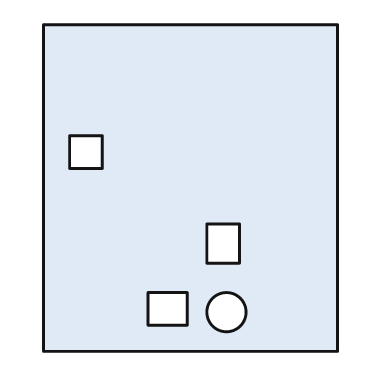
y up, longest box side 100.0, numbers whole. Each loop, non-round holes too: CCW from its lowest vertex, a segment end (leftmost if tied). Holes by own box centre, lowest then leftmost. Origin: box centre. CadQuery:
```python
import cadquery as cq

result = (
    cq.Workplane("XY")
    .moveTo(-45.0, -50.0)
    .lineTo(45.0, -50.0)
    .lineTo(45.0, 50.0)
    .lineTo(-45.0, 50.0)
    .close()
    .moveTo(11.0, -38.0)
    .circle(6.0)
    .moveTo(-13.0, -42.0)
    .lineTo(-1.0, -42.0)
    .lineTo(-1.0, -32.0)
    .lineTo(-13.0, -32.0)
    .close()
    .moveTo(5.0, -23.0)
    .lineTo(15.0, -23.0)
    .lineTo(15.0, -11.0)
    .lineTo(5.0, -11.0)
    .close()
    .moveTo(-37.0, 6.0)
    .lineTo(-27.0, 6.0)
    .lineTo(-27.0, 16.0)
    .lineTo(-37.0, 16.0)
    .close()
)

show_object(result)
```